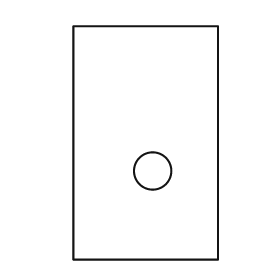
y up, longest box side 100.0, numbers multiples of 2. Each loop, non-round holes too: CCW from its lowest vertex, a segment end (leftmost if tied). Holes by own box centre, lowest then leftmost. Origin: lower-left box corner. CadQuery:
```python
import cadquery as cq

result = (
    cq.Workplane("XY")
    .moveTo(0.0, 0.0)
    .lineTo(62.0, 0.0)
    .lineTo(62.0, 100.0)
    .lineTo(0.0, 100.0)
    .close()
    .moveTo(34.0, 38.0)
    .circle(8.0)
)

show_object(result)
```